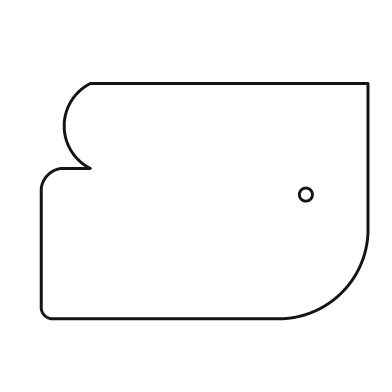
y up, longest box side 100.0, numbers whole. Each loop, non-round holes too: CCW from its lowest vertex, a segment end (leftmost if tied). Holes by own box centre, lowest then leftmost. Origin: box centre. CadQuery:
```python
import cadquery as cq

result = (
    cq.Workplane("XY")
    .moveTo(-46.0, -36.0)
    .lineTo(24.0, -36.0)
    .threePointArc((42.0, -28.0), (50.0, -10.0))
    .lineTo(50.0, 36.0)
    .lineTo(-35.0, 36.0)
    .threePointArc((-43.0, 23.0), (-35.0, 10.0))
    .lineTo(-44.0, 10.0)
    .threePointArc((-48.0, 8.0), (-50.0, 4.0))
    .lineTo(-50.0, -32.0)
    .threePointArc((-49.0, -35.0), (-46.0, -36.0))
    .close()
    .moveTo(31.0, 2.0)
    .circle(2.0)
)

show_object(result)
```